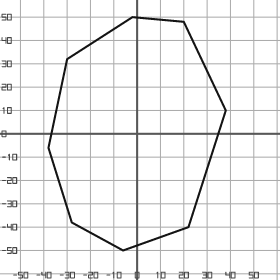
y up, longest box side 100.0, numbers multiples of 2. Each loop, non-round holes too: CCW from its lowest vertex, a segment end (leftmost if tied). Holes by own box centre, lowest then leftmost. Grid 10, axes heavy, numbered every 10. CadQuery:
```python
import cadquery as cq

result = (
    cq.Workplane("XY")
    .moveTo(-6.0, -50.0)
    .lineTo(22.0, -40.0)
    .lineTo(38.0, 10.0)
    .lineTo(20.0, 48.0)
    .lineTo(-2.0, 50.0)
    .lineTo(-30.0, 32.0)
    .lineTo(-38.0, -6.0)
    .lineTo(-28.0, -38.0)
    .close()
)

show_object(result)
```